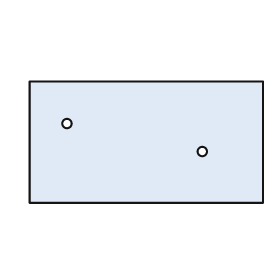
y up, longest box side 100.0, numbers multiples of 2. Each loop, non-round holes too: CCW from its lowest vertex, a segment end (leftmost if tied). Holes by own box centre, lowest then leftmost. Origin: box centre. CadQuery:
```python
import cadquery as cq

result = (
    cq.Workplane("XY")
    .moveTo(-50.0, -26.0)
    .lineTo(50.0, -26.0)
    .lineTo(50.0, 26.0)
    .lineTo(-50.0, 26.0)
    .close()
    .moveTo(24.0, -4.0)
    .circle(2.0)
    .moveTo(-34.0, 8.0)
    .circle(2.0)
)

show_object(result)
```